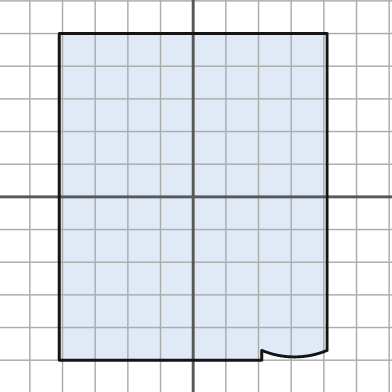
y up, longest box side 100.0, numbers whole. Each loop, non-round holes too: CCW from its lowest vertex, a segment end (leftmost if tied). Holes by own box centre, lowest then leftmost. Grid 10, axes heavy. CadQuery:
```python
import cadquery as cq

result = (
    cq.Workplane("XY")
    .moveTo(-41.0, -50.0)
    .lineTo(21.0, -50.0)
    .lineTo(21.0, -47.0)
    .threePointArc((31.0, -49.0), (41.0, -47.0))
    .lineTo(41.0, 50.0)
    .lineTo(-41.0, 50.0)
    .close()
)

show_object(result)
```